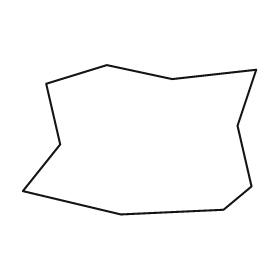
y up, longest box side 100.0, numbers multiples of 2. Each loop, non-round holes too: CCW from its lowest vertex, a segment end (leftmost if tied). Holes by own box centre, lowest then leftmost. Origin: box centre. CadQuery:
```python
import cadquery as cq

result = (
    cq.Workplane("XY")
    .moveTo(-8.0, -32.0)
    .lineTo(36.0, -30.0)
    .lineTo(48.0, -20.0)
    .lineTo(42.0, 6.0)
    .lineTo(50.0, 30.0)
    .lineTo(14.0, 26.0)
    .lineTo(-14.0, 32.0)
    .lineTo(-40.0, 24.0)
    .lineTo(-34.0, -2.0)
    .lineTo(-50.0, -22.0)
    .close()
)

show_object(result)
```